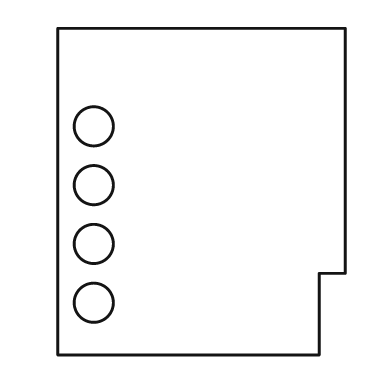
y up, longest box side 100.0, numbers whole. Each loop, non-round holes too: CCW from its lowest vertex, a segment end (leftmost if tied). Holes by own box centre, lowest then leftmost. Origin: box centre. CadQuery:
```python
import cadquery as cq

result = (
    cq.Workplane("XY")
    .moveTo(-44.0, -50.0)
    .lineTo(36.0, -50.0)
    .lineTo(36.0, -25.0)
    .lineTo(44.0, -25.0)
    .lineTo(44.0, 50.0)
    .lineTo(-44.0, 50.0)
    .close()
    .moveTo(-33.0, -34.0)
    .circle(6.0)
    .moveTo(-33.0, -16.0)
    .circle(6.0)
    .moveTo(-33.0, 2.0)
    .circle(6.0)
    .moveTo(-33.0, 20.0)
    .circle(6.0)
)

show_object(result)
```